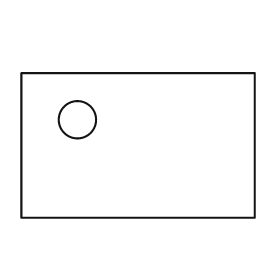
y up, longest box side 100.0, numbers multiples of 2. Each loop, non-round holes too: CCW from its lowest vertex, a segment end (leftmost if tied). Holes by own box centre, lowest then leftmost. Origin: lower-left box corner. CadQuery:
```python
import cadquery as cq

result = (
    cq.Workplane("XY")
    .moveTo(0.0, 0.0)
    .lineTo(100.0, 0.0)
    .lineTo(100.0, 62.0)
    .lineTo(0.0, 62.0)
    .close()
    .moveTo(24.0, 42.0)
    .circle(8.0)
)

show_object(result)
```